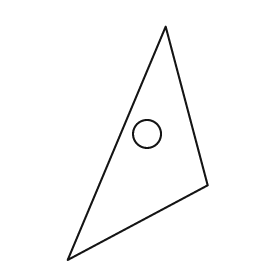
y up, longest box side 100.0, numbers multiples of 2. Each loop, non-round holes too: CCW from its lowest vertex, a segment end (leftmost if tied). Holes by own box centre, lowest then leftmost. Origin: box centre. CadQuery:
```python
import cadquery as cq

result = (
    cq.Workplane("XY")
    .moveTo(-30.0, -50.0)
    .lineTo(30.0, -18.0)
    .lineTo(12.0, 50.0)
    .close()
    .moveTo(4.0, 4.0)
    .circle(6.0)
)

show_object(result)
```